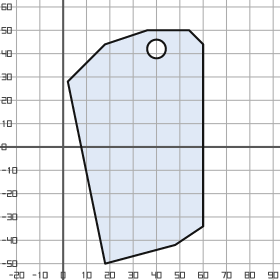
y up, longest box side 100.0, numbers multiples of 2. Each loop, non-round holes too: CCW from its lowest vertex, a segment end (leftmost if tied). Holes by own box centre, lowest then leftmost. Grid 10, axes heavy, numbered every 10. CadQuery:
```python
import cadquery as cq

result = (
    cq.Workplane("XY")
    .moveTo(18.0, -50.0)
    .lineTo(48.0, -42.0)
    .lineTo(60.0, -34.0)
    .lineTo(60.0, 44.0)
    .lineTo(54.0, 50.0)
    .lineTo(36.0, 50.0)
    .lineTo(18.0, 44.0)
    .lineTo(2.0, 28.0)
    .close()
    .moveTo(40.0, 42.0)
    .circle(4.0)
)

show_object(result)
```